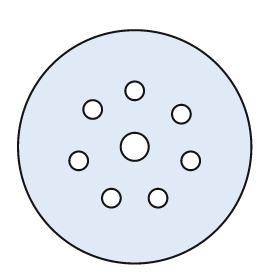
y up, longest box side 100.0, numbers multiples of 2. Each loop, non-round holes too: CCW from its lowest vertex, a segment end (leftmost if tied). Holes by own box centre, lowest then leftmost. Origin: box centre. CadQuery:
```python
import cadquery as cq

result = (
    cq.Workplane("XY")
    .moveTo(0.0, 0.0)
    .circle(50.0)
    .moveTo(-10.0, -22.0)
    .circle(4.0)
    .moveTo(10.0, -22.0)
    .circle(4.0)
    .moveTo(-24.0, -6.0)
    .circle(4.0)
    .moveTo(24.0, -6.0)
    .circle(4.0)
    .moveTo(0.0, 0.0)
    .circle(6.0)
    .moveTo(20.0, 14.0)
    .circle(4.0)
    .moveTo(-18.0, 16.0)
    .circle(4.0)
    .moveTo(0.0, 24.0)
    .circle(4.0)
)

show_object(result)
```